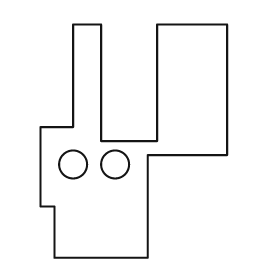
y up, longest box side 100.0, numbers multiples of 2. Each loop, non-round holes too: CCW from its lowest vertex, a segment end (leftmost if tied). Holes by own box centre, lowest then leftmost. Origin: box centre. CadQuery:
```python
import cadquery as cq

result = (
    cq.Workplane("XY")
    .moveTo(-34.0, -50.0)
    .lineTo(6.0, -50.0)
    .lineTo(6.0, -6.0)
    .lineTo(40.0, -6.0)
    .lineTo(40.0, 50.0)
    .lineTo(10.0, 50.0)
    .lineTo(10.0, 0.0)
    .lineTo(-14.0, 0.0)
    .lineTo(-14.0, 50.0)
    .lineTo(-26.0, 50.0)
    .lineTo(-26.0, 6.0)
    .lineTo(-40.0, 6.0)
    .lineTo(-40.0, -28.0)
    .lineTo(-34.0, -28.0)
    .close()
    .moveTo(-26.0, -10.0)
    .circle(6.0)
    .moveTo(-8.0, -10.0)
    .circle(6.0)
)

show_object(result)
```